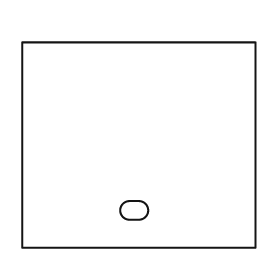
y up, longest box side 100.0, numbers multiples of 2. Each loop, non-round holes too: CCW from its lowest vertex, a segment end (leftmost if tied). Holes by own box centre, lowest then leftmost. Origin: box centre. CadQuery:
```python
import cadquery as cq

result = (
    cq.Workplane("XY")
    .moveTo(-50.0, -44.0)
    .lineTo(50.0, -44.0)
    .lineTo(50.0, 44.0)
    .lineTo(-50.0, 44.0)
    .close()
    .moveTo(-4.0, -32.0)
    .lineTo(0.0, -32.0)
    .threePointArc((4.0, -28.0), (0.0, -24.0))
    .lineTo(-4.0, -24.0)
    .threePointArc((-8.0, -28.0), (-4.0, -32.0))
    .close()
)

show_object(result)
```